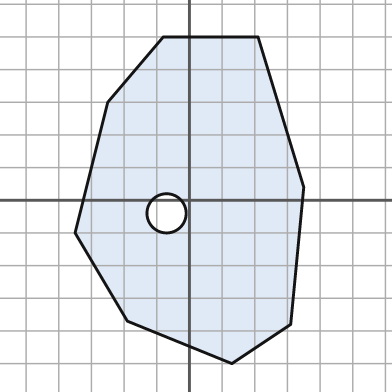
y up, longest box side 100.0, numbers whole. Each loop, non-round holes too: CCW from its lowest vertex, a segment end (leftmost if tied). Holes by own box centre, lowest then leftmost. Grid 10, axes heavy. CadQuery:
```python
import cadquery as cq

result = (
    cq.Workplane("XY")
    .moveTo(13.0, -50.0)
    .lineTo(31.0, -38.0)
    .lineTo(35.0, 4.0)
    .lineTo(21.0, 50.0)
    .lineTo(-8.0, 50.0)
    .lineTo(-25.0, 30.0)
    .lineTo(-35.0, -10.0)
    .lineTo(-19.0, -37.0)
    .close()
    .moveTo(-7.0, -4.0)
    .circle(6.0)
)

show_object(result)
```